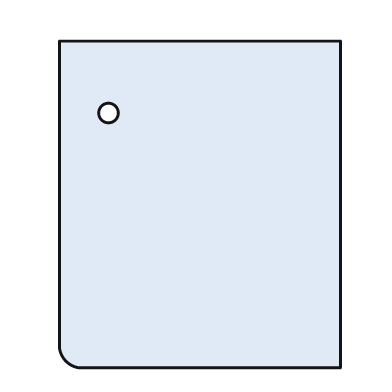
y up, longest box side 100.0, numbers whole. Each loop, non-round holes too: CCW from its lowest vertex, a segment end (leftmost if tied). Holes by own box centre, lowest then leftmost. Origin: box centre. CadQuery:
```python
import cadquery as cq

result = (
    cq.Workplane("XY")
    .moveTo(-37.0, -50.0)
    .lineTo(43.0, -50.0)
    .lineTo(43.0, 50.0)
    .lineTo(-43.0, 50.0)
    .lineTo(-43.0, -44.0)
    .threePointArc((-41.0, -48.0), (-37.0, -50.0))
    .close()
    .moveTo(-28.0, 28.0)
    .circle(3.0)
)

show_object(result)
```